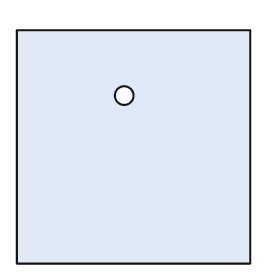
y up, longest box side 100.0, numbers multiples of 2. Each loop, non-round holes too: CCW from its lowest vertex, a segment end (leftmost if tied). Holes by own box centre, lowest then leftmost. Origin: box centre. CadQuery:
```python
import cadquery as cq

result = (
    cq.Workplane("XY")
    .moveTo(-50.0, -50.0)
    .lineTo(50.0, -50.0)
    .lineTo(50.0, 50.0)
    .lineTo(-50.0, 50.0)
    .close()
    .moveTo(-4.0, 22.0)
    .circle(4.0)
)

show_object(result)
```